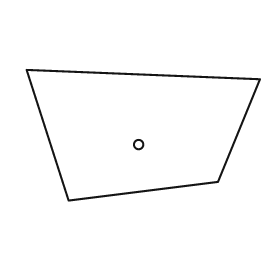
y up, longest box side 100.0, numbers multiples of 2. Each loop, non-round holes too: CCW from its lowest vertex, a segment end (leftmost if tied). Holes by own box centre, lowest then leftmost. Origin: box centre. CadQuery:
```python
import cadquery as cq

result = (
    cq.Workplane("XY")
    .moveTo(-32.0, -28.0)
    .lineTo(32.0, -20.0)
    .lineTo(50.0, 24.0)
    .lineTo(-50.0, 28.0)
    .close()
    .moveTo(-2.0, -4.0)
    .circle(2.0)
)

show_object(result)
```